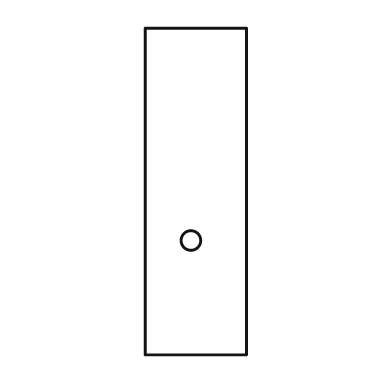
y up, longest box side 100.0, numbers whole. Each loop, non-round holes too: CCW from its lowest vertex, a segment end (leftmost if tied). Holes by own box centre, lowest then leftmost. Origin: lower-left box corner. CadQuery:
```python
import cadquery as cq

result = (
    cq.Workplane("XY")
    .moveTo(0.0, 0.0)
    .lineTo(31.0, 0.0)
    .lineTo(31.0, 100.0)
    .lineTo(0.0, 100.0)
    .close()
    .moveTo(14.0, 35.0)
    .circle(3.0)
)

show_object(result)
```